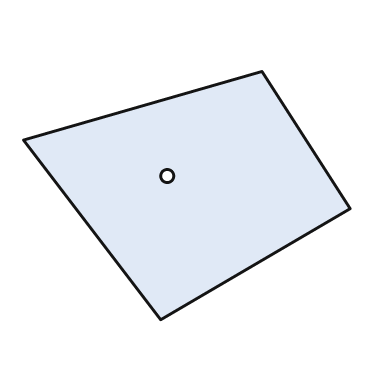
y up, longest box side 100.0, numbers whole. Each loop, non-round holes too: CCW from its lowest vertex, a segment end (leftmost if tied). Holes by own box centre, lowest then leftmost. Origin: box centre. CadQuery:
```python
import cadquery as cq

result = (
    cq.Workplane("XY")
    .moveTo(-8.0, -38.0)
    .lineTo(50.0, -4.0)
    .lineTo(23.0, 38.0)
    .lineTo(-50.0, 17.0)
    .close()
    .moveTo(-6.0, 6.0)
    .circle(2.0)
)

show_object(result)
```